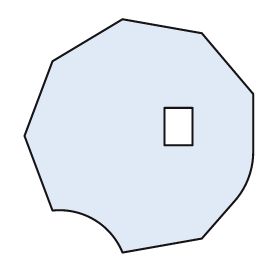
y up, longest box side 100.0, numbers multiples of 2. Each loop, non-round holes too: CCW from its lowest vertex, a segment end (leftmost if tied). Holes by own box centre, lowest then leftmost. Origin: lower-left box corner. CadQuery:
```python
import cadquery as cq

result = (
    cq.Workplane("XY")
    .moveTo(42.0, 0.0)
    .lineTo(76.0, 6.0)
    .lineTo(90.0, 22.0)
    .threePointArc((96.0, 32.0), (98.0, 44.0))
    .lineTo(98.0, 68.0)
    .lineTo(76.0, 94.0)
    .lineTo(42.0, 100.0)
    .lineTo(12.0, 82.0)
    .lineTo(0.0, 50.0)
    .lineTo(12.0, 18.0)
    .threePointArc((30.0, 14.0), (42.0, 0.0))
    .close()
    .moveTo(60.0, 46.0)
    .lineTo(72.0, 46.0)
    .lineTo(72.0, 62.0)
    .lineTo(60.0, 62.0)
    .close()
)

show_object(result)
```